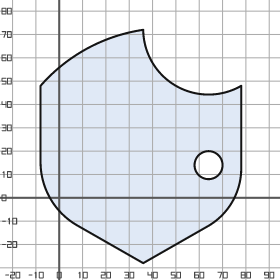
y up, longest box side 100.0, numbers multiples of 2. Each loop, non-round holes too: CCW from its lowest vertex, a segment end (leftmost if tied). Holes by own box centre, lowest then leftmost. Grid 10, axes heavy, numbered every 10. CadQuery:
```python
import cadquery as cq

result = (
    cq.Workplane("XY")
    .moveTo(36.0, -28.0)
    .lineTo(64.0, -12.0)
    .threePointArc((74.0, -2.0), (78.0, 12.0))
    .lineTo(78.0, 48.0)
    .threePointArc((50.0, 48.0), (36.0, 72.0))
    .threePointArc((12.0, 64.0), (-8.0, 48.0))
    .lineTo(-8.0, 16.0)
    .threePointArc((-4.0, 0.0), (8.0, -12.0))
    .close()
    .moveTo(64.0, 14.0)
    .circle(6.0)
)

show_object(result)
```